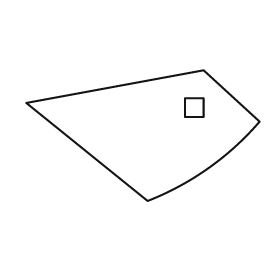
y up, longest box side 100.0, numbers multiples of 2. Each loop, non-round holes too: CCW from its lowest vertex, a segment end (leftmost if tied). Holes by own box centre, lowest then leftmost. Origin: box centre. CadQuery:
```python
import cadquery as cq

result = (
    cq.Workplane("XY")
    .moveTo(2.0, -28.0)
    .threePointArc((28.0, -14.0), (50.0, 6.0))
    .lineTo(26.0, 28.0)
    .lineTo(-50.0, 14.0)
    .close()
    .moveTo(18.0, 8.0)
    .lineTo(26.0, 8.0)
    .lineTo(26.0, 16.0)
    .lineTo(18.0, 16.0)
    .close()
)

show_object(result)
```